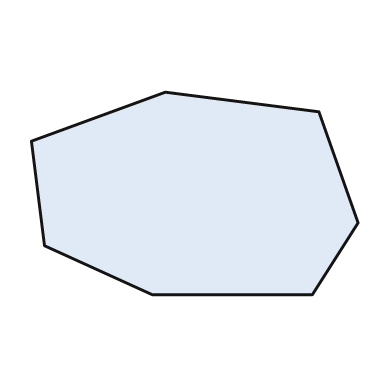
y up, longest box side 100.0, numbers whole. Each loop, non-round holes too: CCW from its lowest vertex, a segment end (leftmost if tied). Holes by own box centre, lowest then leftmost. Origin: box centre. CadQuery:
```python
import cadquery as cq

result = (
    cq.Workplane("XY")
    .moveTo(-13.0, -31.0)
    .lineTo(36.0, -31.0)
    .lineTo(50.0, -9.0)
    .lineTo(38.0, 25.0)
    .lineTo(-9.0, 31.0)
    .lineTo(-50.0, 16.0)
    .lineTo(-46.0, -16.0)
    .close()
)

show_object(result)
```